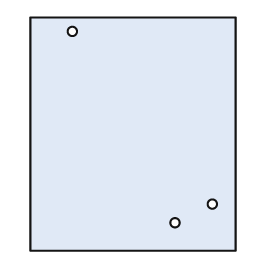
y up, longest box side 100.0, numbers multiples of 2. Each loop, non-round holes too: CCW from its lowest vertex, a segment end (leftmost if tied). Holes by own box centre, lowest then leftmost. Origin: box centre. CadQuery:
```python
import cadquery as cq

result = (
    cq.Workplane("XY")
    .moveTo(-44.0, -50.0)
    .lineTo(44.0, -50.0)
    .lineTo(44.0, 50.0)
    .lineTo(-44.0, 50.0)
    .close()
    .moveTo(18.0, -38.0)
    .circle(2.0)
    .moveTo(34.0, -30.0)
    .circle(2.0)
    .moveTo(-26.0, 44.0)
    .circle(2.0)
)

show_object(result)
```